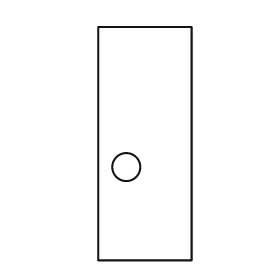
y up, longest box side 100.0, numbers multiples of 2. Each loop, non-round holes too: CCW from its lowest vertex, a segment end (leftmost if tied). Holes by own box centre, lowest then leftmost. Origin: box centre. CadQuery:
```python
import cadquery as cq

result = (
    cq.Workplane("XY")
    .moveTo(-20.0, -50.0)
    .lineTo(20.0, -50.0)
    .lineTo(20.0, 50.0)
    .lineTo(-20.0, 50.0)
    .close()
    .moveTo(-8.0, -10.0)
    .circle(6.0)
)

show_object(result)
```